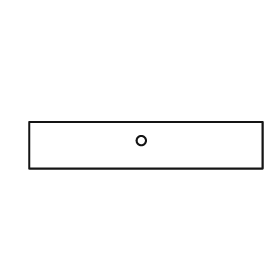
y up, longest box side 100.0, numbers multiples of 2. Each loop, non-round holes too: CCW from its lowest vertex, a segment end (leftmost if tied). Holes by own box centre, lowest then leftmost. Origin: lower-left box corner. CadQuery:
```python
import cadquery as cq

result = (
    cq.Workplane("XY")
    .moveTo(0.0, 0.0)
    .lineTo(100.0, 0.0)
    .lineTo(100.0, 20.0)
    .lineTo(0.0, 20.0)
    .close()
    .moveTo(48.0, 12.0)
    .circle(2.0)
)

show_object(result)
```